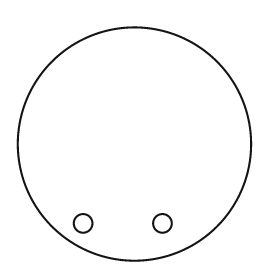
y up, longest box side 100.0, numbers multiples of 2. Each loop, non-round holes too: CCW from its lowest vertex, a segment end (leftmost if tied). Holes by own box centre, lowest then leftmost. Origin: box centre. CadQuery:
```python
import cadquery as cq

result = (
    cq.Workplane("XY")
    .moveTo(0.0, 0.0)
    .circle(50.0)
    .moveTo(-22.0, -34.0)
    .circle(4.0)
    .moveTo(12.0, -34.0)
    .circle(4.0)
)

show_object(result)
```